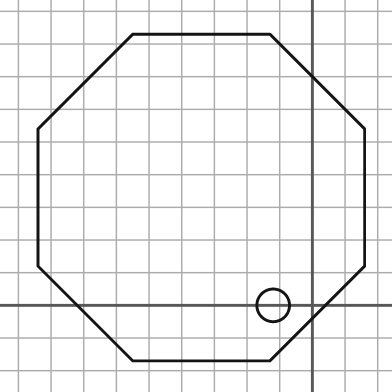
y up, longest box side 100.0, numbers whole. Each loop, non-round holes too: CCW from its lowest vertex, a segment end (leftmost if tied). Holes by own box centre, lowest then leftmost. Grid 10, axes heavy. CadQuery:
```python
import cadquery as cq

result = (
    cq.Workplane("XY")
    .moveTo(-55.0, -17.0)
    .lineTo(-13.0, -17.0)
    .lineTo(16.0, 12.0)
    .lineTo(16.0, 54.0)
    .lineTo(-13.0, 83.0)
    .lineTo(-55.0, 83.0)
    .lineTo(-84.0, 54.0)
    .lineTo(-84.0, 12.0)
    .close()
    .moveTo(-12.0, 0.0)
    .circle(5.0)
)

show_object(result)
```